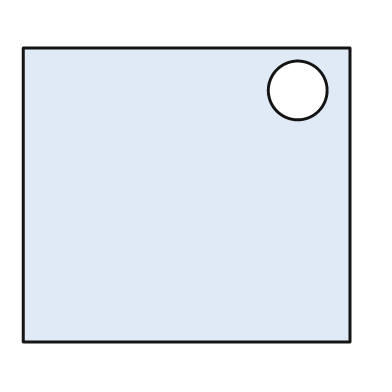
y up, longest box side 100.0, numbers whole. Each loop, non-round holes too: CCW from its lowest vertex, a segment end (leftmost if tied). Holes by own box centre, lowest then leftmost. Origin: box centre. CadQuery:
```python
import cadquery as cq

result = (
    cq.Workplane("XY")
    .moveTo(-50.0, -45.0)
    .lineTo(50.0, -45.0)
    .lineTo(50.0, 45.0)
    .lineTo(-50.0, 45.0)
    .close()
    .moveTo(34.0, 32.0)
    .circle(9.0)
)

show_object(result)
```